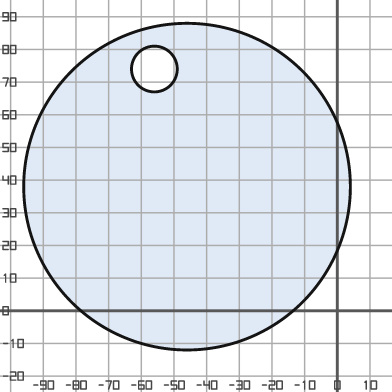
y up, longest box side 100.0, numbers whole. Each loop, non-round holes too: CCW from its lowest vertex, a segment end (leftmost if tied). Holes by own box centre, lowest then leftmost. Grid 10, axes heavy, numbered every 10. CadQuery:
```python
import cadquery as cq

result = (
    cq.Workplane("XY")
    .moveTo(-46.0, 38.0)
    .circle(50.0)
    .moveTo(-56.0, 74.0)
    .circle(7.0)
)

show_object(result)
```